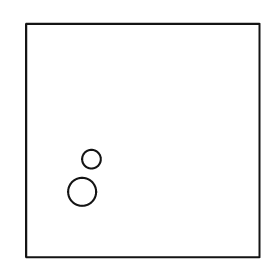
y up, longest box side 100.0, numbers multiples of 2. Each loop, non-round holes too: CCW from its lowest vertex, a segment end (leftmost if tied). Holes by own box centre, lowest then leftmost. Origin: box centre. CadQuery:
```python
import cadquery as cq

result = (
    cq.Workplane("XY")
    .moveTo(-50.0, -50.0)
    .lineTo(50.0, -50.0)
    .lineTo(50.0, 50.0)
    .lineTo(-50.0, 50.0)
    .close()
    .moveTo(-26.0, -22.0)
    .circle(6.0)
    .moveTo(-22.0, -8.0)
    .circle(4.0)
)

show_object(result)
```